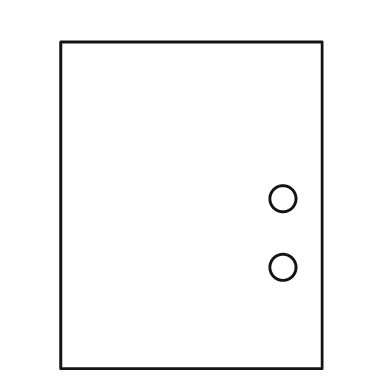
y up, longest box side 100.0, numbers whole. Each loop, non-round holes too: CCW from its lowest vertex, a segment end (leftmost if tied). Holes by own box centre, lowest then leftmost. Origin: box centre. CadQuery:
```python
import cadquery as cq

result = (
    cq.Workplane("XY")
    .moveTo(-40.0, -50.0)
    .lineTo(40.0, -50.0)
    .lineTo(40.0, 50.0)
    .lineTo(-40.0, 50.0)
    .close()
    .moveTo(28.0, -19.0)
    .circle(4.0)
    .moveTo(28.0, 2.0)
    .circle(4.0)
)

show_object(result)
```